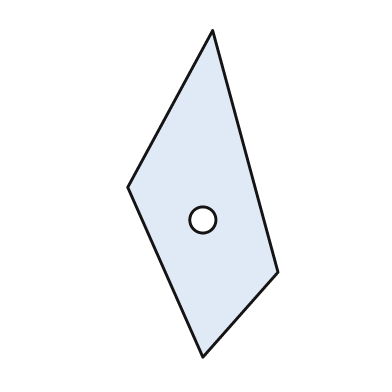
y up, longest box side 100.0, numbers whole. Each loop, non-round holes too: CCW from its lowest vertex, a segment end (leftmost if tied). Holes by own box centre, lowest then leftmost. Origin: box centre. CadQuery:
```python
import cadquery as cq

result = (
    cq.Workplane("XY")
    .moveTo(0.0, -50.0)
    .lineTo(23.0, -24.0)
    .lineTo(3.0, 50.0)
    .lineTo(-23.0, 2.0)
    .close()
    .moveTo(0.0, -8.0)
    .circle(4.0)
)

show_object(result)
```